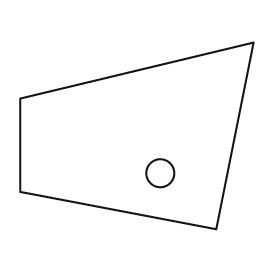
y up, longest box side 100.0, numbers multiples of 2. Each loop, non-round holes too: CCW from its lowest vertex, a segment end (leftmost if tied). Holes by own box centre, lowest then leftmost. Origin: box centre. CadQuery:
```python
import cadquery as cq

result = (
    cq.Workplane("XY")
    .moveTo(34.0, -40.0)
    .lineTo(50.0, 40.0)
    .lineTo(-50.0, 16.0)
    .lineTo(-50.0, -24.0)
    .close()
    .moveTo(10.0, -16.0)
    .circle(6.0)
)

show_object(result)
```